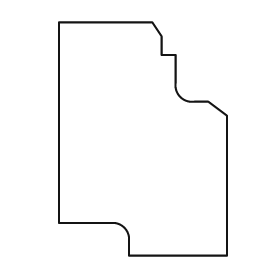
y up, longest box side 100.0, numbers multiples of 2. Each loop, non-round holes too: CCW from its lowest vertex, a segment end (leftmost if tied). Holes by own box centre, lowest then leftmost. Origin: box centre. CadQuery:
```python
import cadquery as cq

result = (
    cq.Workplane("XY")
    .moveTo(-6.0, -50.0)
    .lineTo(36.0, -50.0)
    .lineTo(36.0, 10.0)
    .lineTo(28.0, 16.0)
    .lineTo(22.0, 16.0)
    .threePointArc((16.0, 18.0), (14.0, 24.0))
    .lineTo(14.0, 36.0)
    .lineTo(8.0, 36.0)
    .lineTo(8.0, 44.0)
    .lineTo(4.0, 50.0)
    .lineTo(-36.0, 50.0)
    .lineTo(-36.0, -36.0)
    .lineTo(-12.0, -36.0)
    .threePointArc((-8.0, -38.0), (-6.0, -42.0))
    .close()
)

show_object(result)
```